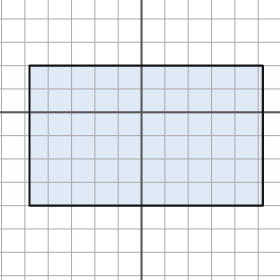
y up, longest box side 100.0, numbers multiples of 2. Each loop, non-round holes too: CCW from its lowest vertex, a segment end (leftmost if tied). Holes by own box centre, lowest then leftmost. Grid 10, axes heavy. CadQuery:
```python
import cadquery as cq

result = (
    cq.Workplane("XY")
    .moveTo(-48.0, -40.0)
    .lineTo(52.0, -40.0)
    .lineTo(52.0, 20.0)
    .lineTo(-48.0, 20.0)
    .close()
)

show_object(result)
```